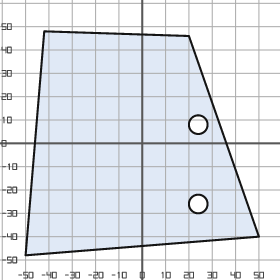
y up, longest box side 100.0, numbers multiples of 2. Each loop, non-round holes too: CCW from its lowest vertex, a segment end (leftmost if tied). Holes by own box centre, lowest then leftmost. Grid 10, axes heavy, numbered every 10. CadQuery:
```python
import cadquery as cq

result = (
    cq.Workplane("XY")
    .moveTo(-50.0, -48.0)
    .lineTo(50.0, -40.0)
    .lineTo(20.0, 46.0)
    .lineTo(-42.0, 48.0)
    .close()
    .moveTo(24.0, -26.0)
    .circle(4.0)
    .moveTo(24.0, 8.0)
    .circle(4.0)
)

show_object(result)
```